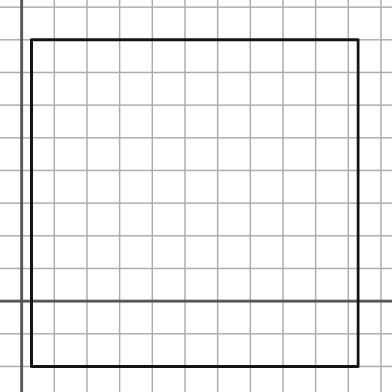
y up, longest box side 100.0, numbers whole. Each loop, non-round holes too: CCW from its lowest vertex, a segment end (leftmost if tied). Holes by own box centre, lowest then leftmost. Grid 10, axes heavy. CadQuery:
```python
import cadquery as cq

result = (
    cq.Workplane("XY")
    .moveTo(3.0, -20.0)
    .lineTo(103.0, -20.0)
    .lineTo(103.0, 80.0)
    .lineTo(3.0, 80.0)
    .close()
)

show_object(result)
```